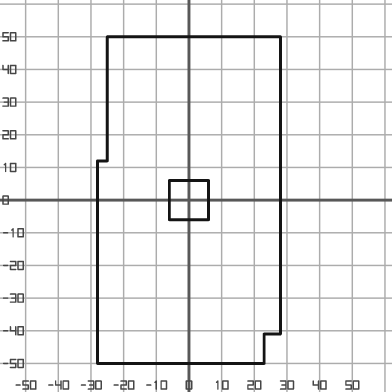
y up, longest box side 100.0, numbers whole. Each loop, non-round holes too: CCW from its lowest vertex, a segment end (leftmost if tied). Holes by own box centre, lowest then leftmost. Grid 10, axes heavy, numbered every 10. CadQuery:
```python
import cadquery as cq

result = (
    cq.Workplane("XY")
    .moveTo(-28.0, -50.0)
    .lineTo(23.0, -50.0)
    .lineTo(23.0, -41.0)
    .lineTo(28.0, -41.0)
    .lineTo(28.0, 50.0)
    .lineTo(-25.0, 50.0)
    .lineTo(-25.0, 12.0)
    .lineTo(-28.0, 12.0)
    .close()
    .moveTo(-6.0, -6.0)
    .lineTo(6.0, -6.0)
    .lineTo(6.0, 6.0)
    .lineTo(-6.0, 6.0)
    .close()
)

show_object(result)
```